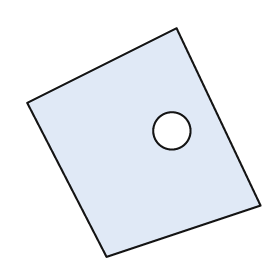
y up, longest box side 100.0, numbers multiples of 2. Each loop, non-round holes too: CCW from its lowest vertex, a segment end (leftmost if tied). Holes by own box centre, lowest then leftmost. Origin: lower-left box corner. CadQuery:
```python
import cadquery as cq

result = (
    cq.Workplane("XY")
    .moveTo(34.0, 0.0)
    .lineTo(100.0, 22.0)
    .lineTo(64.0, 98.0)
    .lineTo(0.0, 66.0)
    .close()
    .moveTo(62.0, 54.0)
    .circle(8.0)
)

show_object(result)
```